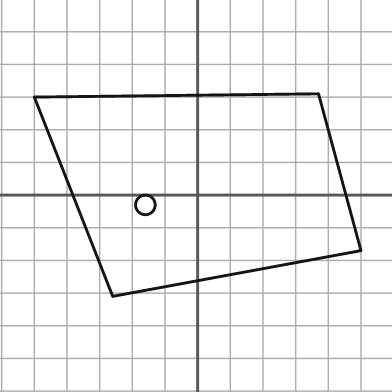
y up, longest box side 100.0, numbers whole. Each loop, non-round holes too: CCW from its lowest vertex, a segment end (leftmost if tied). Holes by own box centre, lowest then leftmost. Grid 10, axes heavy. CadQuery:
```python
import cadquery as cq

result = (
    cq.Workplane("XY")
    .moveTo(-26.0, -31.0)
    .lineTo(50.0, -17.0)
    .lineTo(37.0, 31.0)
    .lineTo(-50.0, 30.0)
    .close()
    .moveTo(-16.0, -3.0)
    .circle(3.0)
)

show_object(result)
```